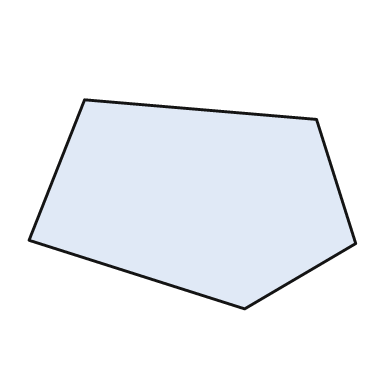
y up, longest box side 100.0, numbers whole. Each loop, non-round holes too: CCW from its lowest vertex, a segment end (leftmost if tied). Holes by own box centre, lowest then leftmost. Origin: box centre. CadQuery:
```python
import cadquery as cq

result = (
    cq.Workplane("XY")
    .moveTo(16.0, -32.0)
    .lineTo(50.0, -12.0)
    .lineTo(38.0, 26.0)
    .lineTo(-33.0, 32.0)
    .lineTo(-50.0, -11.0)
    .close()
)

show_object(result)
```